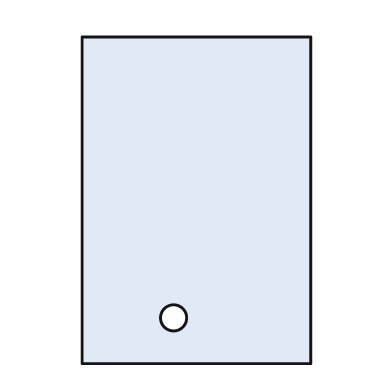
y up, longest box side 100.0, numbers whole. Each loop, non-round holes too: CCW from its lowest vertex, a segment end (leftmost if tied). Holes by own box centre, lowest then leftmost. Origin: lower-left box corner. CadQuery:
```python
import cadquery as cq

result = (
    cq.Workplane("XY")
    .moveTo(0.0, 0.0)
    .lineTo(70.0, 0.0)
    .lineTo(70.0, 100.0)
    .lineTo(0.0, 100.0)
    .close()
    .moveTo(28.0, 14.0)
    .circle(4.0)
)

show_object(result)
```